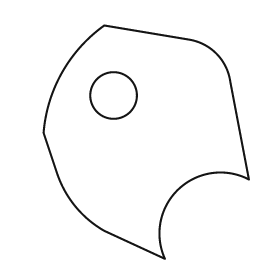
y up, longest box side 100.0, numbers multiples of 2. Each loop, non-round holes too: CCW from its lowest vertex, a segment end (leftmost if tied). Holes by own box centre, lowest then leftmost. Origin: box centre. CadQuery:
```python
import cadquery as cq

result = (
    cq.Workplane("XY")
    .moveTo(8.0, -50.0)
    .threePointArc((14.0, -20.0), (44.0, -16.0))
    .lineTo(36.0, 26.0)
    .threePointArc((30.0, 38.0), (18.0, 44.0))
    .lineTo(-18.0, 50.0)
    .threePointArc((-36.0, 30.0), (-44.0, 4.0))
    .lineTo(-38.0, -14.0)
    .threePointArc((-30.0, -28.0), (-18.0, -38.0))
    .close()
    .moveTo(-14.0, 20.0)
    .circle(10.0)
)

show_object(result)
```